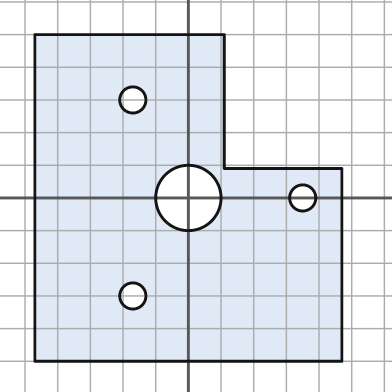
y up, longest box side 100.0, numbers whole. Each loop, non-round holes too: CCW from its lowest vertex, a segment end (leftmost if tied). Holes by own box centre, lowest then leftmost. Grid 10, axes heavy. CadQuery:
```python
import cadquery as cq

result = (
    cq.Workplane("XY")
    .moveTo(-47.0, -50.0)
    .lineTo(47.0, -50.0)
    .lineTo(47.0, 9.0)
    .lineTo(11.0, 9.0)
    .lineTo(11.0, 50.0)
    .lineTo(-47.0, 50.0)
    .close()
    .moveTo(-17.0, -30.0)
    .circle(4.0)
    .moveTo(0.0, 0.0)
    .circle(10.0)
    .moveTo(35.0, 0.0)
    .circle(4.0)
    .moveTo(-17.0, 30.0)
    .circle(4.0)
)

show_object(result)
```